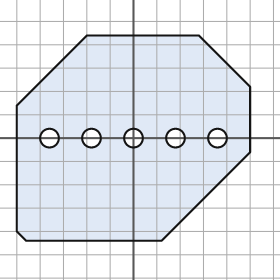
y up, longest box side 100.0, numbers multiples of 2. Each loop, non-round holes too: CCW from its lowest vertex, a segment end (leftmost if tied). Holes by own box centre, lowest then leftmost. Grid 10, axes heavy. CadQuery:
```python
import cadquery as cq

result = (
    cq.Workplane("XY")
    .moveTo(-46.0, -44.0)
    .lineTo(12.0, -44.0)
    .lineTo(50.0, -6.0)
    .lineTo(50.0, 22.0)
    .lineTo(28.0, 44.0)
    .lineTo(-20.0, 44.0)
    .lineTo(-50.0, 14.0)
    .lineTo(-50.0, -40.0)
    .close()
    .moveTo(-36.0, 0.0)
    .circle(4.0)
    .moveTo(-18.0, 0.0)
    .circle(4.0)
    .moveTo(0.0, 0.0)
    .circle(4.0)
    .moveTo(18.0, 0.0)
    .circle(4.0)
    .moveTo(36.0, 0.0)
    .circle(4.0)
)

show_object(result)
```